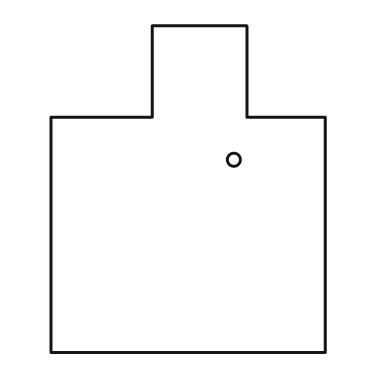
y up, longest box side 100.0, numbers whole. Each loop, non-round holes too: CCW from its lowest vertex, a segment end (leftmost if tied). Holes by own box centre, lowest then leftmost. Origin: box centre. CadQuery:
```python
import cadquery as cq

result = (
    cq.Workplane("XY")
    .moveTo(-42.0, -50.0)
    .lineTo(42.0, -50.0)
    .lineTo(42.0, 22.0)
    .lineTo(18.0, 22.0)
    .lineTo(18.0, 50.0)
    .lineTo(-11.0, 50.0)
    .lineTo(-11.0, 22.0)
    .lineTo(-42.0, 22.0)
    .close()
    .moveTo(14.0, 9.0)
    .circle(2.0)
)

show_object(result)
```